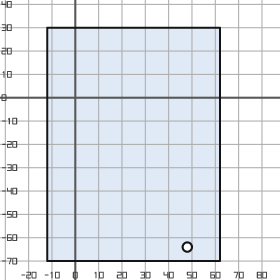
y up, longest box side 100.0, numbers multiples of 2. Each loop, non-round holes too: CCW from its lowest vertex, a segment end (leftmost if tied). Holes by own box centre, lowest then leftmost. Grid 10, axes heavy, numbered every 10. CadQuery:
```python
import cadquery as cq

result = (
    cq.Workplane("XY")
    .moveTo(-12.0, -70.0)
    .lineTo(62.0, -70.0)
    .lineTo(62.0, 30.0)
    .lineTo(-12.0, 30.0)
    .close()
    .moveTo(48.0, -64.0)
    .circle(2.0)
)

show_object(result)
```